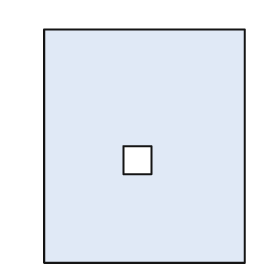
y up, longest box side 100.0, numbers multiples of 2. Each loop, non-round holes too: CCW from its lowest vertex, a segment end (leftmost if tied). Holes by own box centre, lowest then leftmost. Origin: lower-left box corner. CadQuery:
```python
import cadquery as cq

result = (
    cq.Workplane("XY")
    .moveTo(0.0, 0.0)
    .lineTo(86.0, 0.0)
    .lineTo(86.0, 100.0)
    .lineTo(0.0, 100.0)
    .close()
    .moveTo(34.0, 38.0)
    .lineTo(46.0, 38.0)
    .lineTo(46.0, 50.0)
    .lineTo(34.0, 50.0)
    .close()
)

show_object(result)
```